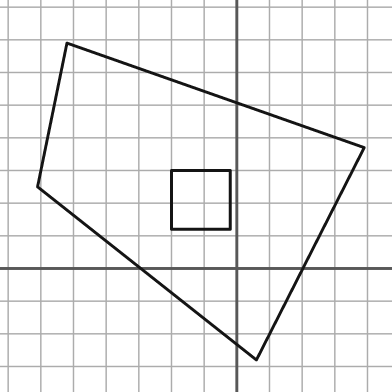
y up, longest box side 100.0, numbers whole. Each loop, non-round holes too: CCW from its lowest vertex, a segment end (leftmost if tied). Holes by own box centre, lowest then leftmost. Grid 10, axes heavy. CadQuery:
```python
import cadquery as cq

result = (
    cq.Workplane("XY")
    .moveTo(6.0, -28.0)
    .lineTo(39.0, 37.0)
    .lineTo(-52.0, 69.0)
    .lineTo(-61.0, 25.0)
    .close()
    .moveTo(-20.0, 12.0)
    .lineTo(-2.0, 12.0)
    .lineTo(-2.0, 30.0)
    .lineTo(-20.0, 30.0)
    .close()
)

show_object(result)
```